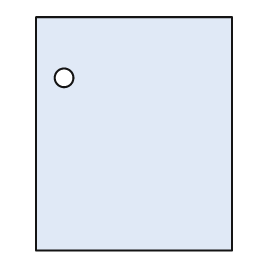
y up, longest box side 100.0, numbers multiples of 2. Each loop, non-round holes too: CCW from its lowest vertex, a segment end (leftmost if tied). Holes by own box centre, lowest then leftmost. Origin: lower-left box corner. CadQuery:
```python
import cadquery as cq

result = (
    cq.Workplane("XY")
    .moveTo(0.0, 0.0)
    .lineTo(84.0, 0.0)
    .lineTo(84.0, 100.0)
    .lineTo(0.0, 100.0)
    .close()
    .moveTo(12.0, 74.0)
    .circle(4.0)
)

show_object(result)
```